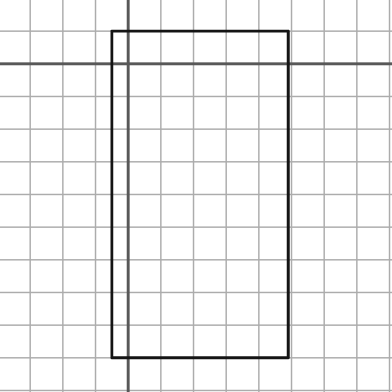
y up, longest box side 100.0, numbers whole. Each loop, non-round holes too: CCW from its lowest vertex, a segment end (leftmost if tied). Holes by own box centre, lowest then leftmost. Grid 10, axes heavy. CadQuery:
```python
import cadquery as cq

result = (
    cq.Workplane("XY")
    .moveTo(-5.0, -90.0)
    .lineTo(49.0, -90.0)
    .lineTo(49.0, 10.0)
    .lineTo(-5.0, 10.0)
    .close()
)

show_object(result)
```